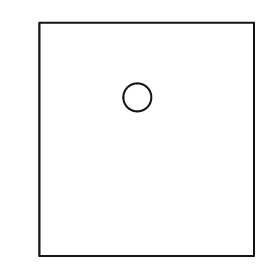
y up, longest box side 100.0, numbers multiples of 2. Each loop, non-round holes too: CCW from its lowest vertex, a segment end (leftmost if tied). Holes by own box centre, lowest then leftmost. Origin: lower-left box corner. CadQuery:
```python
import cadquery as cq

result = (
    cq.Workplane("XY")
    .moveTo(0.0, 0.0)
    .lineTo(92.0, 0.0)
    .lineTo(92.0, 100.0)
    .lineTo(0.0, 100.0)
    .close()
    .moveTo(42.0, 68.0)
    .circle(6.0)
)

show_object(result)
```